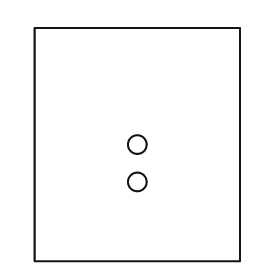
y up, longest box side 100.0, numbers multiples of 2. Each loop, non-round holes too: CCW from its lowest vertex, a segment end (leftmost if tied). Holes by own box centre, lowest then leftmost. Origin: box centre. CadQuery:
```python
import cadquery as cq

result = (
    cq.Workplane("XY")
    .moveTo(-44.0, -50.0)
    .lineTo(44.0, -50.0)
    .lineTo(44.0, 50.0)
    .lineTo(-44.0, 50.0)
    .close()
    .moveTo(0.0, -16.0)
    .circle(4.0)
    .moveTo(0.0, 0.0)
    .circle(4.0)
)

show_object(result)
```